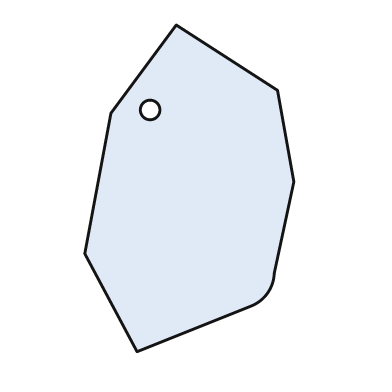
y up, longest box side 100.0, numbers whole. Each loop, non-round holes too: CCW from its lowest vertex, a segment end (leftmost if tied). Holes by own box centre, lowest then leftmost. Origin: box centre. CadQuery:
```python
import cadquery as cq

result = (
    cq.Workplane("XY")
    .moveTo(-16.0, -50.0)
    .lineTo(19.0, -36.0)
    .threePointArc((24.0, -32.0), (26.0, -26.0))
    .lineTo(32.0, 2.0)
    .lineTo(27.0, 30.0)
    .lineTo(-4.0, 50.0)
    .lineTo(-24.0, 23.0)
    .lineTo(-32.0, -20.0)
    .close()
    .moveTo(-12.0, 24.0)
    .circle(3.0)
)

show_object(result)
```